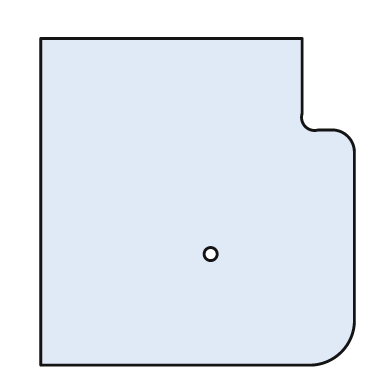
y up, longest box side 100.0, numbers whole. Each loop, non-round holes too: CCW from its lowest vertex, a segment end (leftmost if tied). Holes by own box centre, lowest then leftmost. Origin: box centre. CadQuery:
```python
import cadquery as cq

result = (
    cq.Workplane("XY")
    .moveTo(-48.0, -50.0)
    .lineTo(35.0, -50.0)
    .threePointArc((44.0, -46.0), (48.0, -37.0))
    .lineTo(48.0, 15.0)
    .threePointArc((46.0, 20.0), (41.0, 22.0))
    .lineTo(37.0, 22.0)
    .threePointArc((33.0, 23.0), (32.0, 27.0))
    .lineTo(32.0, 50.0)
    .lineTo(-48.0, 50.0)
    .close()
    .moveTo(4.0, -16.0)
    .circle(2.0)
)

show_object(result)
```